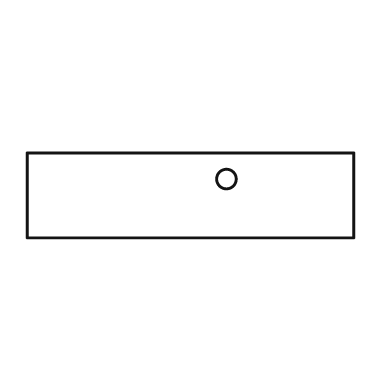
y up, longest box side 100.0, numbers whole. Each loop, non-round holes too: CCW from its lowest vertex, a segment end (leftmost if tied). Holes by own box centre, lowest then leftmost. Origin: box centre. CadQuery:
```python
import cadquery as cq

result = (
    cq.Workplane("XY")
    .moveTo(-50.0, -13.0)
    .lineTo(50.0, -13.0)
    .lineTo(50.0, 13.0)
    .lineTo(-50.0, 13.0)
    .close()
    .moveTo(11.0, 5.0)
    .circle(3.0)
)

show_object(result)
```